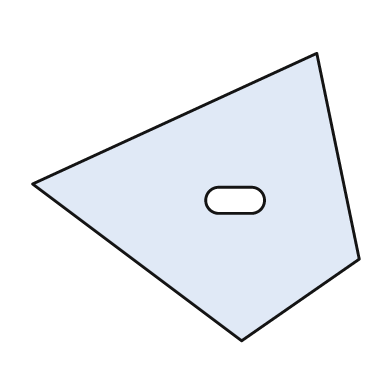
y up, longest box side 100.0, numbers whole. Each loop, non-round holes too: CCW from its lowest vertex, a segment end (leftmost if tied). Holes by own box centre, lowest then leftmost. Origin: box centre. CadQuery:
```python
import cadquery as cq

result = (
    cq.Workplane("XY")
    .moveTo(14.0, -44.0)
    .lineTo(50.0, -19.0)
    .lineTo(37.0, 44.0)
    .lineTo(-50.0, 4.0)
    .close()
    .moveTo(7.0, -5.0)
    .lineTo(17.0, -5.0)
    .threePointArc((21.0, -1.0), (17.0, 3.0))
    .lineTo(7.0, 3.0)
    .threePointArc((3.0, -1.0), (7.0, -5.0))
    .close()
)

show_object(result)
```